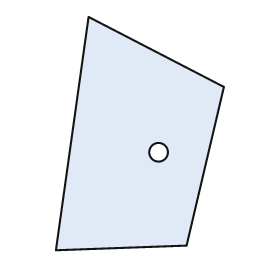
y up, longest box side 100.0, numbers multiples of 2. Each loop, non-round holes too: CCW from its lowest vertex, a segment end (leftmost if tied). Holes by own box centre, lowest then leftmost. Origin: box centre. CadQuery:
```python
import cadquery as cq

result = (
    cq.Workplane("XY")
    .moveTo(-36.0, -50.0)
    .lineTo(20.0, -48.0)
    .lineTo(36.0, 20.0)
    .lineTo(-22.0, 50.0)
    .close()
    .moveTo(8.0, -8.0)
    .circle(4.0)
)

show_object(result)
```